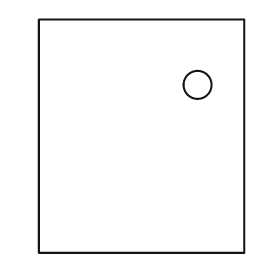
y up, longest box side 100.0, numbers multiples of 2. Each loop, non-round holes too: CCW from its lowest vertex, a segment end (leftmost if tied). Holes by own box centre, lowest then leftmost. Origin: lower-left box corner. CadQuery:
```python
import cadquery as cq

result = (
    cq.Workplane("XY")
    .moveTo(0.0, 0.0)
    .lineTo(88.0, 0.0)
    .lineTo(88.0, 100.0)
    .lineTo(0.0, 100.0)
    .close()
    .moveTo(68.0, 72.0)
    .circle(6.0)
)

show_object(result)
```